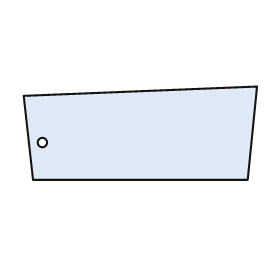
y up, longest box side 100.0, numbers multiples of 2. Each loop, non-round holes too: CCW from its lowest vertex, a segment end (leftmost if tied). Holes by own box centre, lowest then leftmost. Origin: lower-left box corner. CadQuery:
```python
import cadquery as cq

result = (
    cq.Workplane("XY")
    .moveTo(4.0, 0.0)
    .lineTo(96.0, 0.0)
    .lineTo(100.0, 40.0)
    .lineTo(0.0, 36.0)
    .close()
    .moveTo(8.0, 16.0)
    .circle(2.0)
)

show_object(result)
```